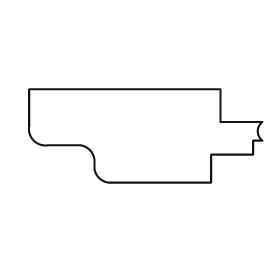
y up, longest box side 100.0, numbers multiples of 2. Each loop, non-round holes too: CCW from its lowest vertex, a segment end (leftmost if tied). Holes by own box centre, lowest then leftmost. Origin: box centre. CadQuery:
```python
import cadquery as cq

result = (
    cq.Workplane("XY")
    .moveTo(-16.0, -20.0)
    .lineTo(28.0, -20.0)
    .lineTo(28.0, -8.0)
    .lineTo(46.0, -8.0)
    .lineTo(46.0, -2.0)
    .lineTo(50.0, -2.0)
    .threePointArc((48.0, 2.0), (50.0, 6.0))
    .lineTo(32.0, 6.0)
    .lineTo(32.0, 20.0)
    .lineTo(-50.0, 20.0)
    .lineTo(-50.0, 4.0)
    .threePointArc((-48.0, -2.0), (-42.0, -4.0))
    .lineTo(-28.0, -4.0)
    .threePointArc((-24.0, -6.0), (-22.0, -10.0))
    .lineTo(-22.0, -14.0)
    .threePointArc((-20.0, -18.0), (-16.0, -20.0))
    .close()
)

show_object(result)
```